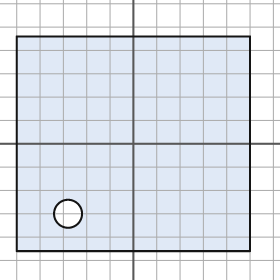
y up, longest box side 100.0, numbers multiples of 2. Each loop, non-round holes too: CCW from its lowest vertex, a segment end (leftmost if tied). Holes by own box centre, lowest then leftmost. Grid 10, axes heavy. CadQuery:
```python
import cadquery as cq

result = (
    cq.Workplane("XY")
    .moveTo(-50.0, -46.0)
    .lineTo(50.0, -46.0)
    .lineTo(50.0, 46.0)
    .lineTo(-50.0, 46.0)
    .close()
    .moveTo(-28.0, -30.0)
    .circle(6.0)
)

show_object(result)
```